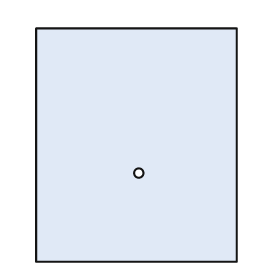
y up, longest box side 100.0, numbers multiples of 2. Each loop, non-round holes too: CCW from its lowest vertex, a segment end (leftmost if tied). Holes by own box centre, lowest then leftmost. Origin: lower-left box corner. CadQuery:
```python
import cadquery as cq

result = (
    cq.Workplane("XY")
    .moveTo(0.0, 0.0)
    .lineTo(86.0, 0.0)
    .lineTo(86.0, 100.0)
    .lineTo(0.0, 100.0)
    .close()
    .moveTo(44.0, 38.0)
    .circle(2.0)
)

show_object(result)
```